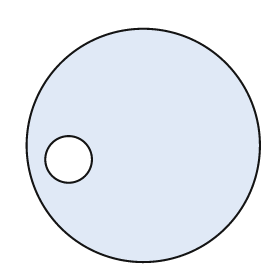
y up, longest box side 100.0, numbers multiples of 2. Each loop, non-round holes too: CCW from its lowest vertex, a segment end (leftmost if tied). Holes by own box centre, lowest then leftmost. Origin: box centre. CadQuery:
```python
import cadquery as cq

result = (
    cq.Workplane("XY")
    .moveTo(0.0, 0.0)
    .circle(50.0)
    .moveTo(-32.0, -6.0)
    .circle(10.0)
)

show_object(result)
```